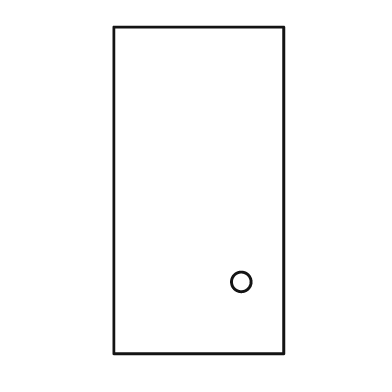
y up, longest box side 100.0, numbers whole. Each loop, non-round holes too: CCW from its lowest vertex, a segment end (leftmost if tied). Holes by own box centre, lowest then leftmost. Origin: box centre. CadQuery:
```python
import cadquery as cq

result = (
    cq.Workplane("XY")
    .moveTo(-26.0, -50.0)
    .lineTo(26.0, -50.0)
    .lineTo(26.0, 50.0)
    .lineTo(-26.0, 50.0)
    .close()
    .moveTo(13.0, -28.0)
    .circle(3.0)
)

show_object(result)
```